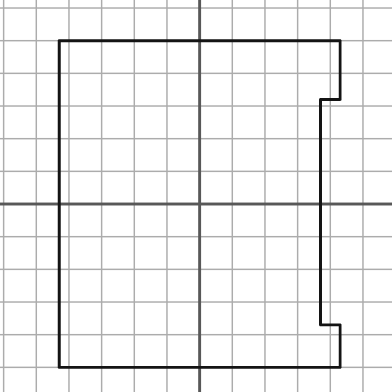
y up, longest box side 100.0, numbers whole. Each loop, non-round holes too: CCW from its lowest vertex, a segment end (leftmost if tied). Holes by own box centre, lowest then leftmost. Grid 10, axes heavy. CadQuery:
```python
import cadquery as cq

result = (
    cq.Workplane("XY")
    .moveTo(-43.0, -50.0)
    .lineTo(43.0, -50.0)
    .lineTo(43.0, -37.0)
    .lineTo(37.0, -37.0)
    .lineTo(37.0, 32.0)
    .lineTo(43.0, 32.0)
    .lineTo(43.0, 50.0)
    .lineTo(-43.0, 50.0)
    .close()
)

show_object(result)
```